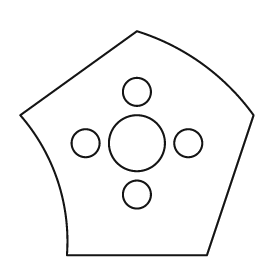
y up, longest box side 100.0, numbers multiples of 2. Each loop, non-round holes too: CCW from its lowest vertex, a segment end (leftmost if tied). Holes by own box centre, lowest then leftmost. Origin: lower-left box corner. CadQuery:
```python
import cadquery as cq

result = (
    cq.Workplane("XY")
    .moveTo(20.0, 0.0)
    .lineTo(80.0, 0.0)
    .lineTo(100.0, 60.0)
    .threePointArc((78.0, 82.0), (50.0, 96.0))
    .lineTo(0.0, 60.0)
    .threePointArc((16.0, 32.0), (20.0, 0.0))
    .close()
    .moveTo(50.0, 26.0)
    .circle(6.0)
    .moveTo(28.0, 48.0)
    .circle(6.0)
    .moveTo(50.0, 48.0)
    .circle(12.0)
    .moveTo(72.0, 48.0)
    .circle(6.0)
    .moveTo(50.0, 70.0)
    .circle(6.0)
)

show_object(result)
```